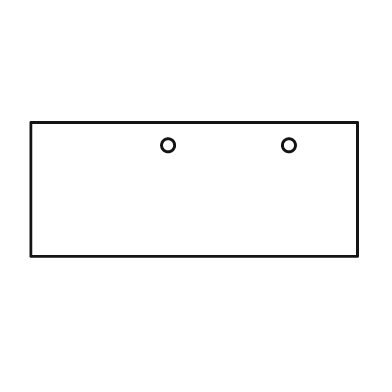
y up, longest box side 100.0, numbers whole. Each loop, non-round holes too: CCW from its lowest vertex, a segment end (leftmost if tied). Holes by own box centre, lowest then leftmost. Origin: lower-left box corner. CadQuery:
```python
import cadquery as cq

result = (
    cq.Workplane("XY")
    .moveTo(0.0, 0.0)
    .lineTo(100.0, 0.0)
    .lineTo(100.0, 41.0)
    .lineTo(0.0, 41.0)
    .close()
    .moveTo(42.0, 34.0)
    .circle(2.0)
    .moveTo(79.0, 34.0)
    .circle(2.0)
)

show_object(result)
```